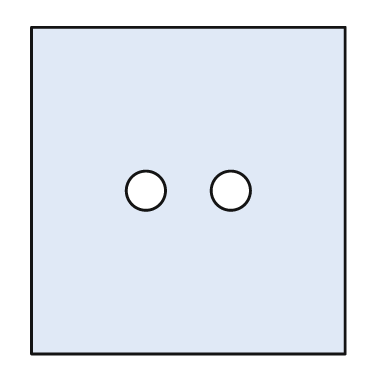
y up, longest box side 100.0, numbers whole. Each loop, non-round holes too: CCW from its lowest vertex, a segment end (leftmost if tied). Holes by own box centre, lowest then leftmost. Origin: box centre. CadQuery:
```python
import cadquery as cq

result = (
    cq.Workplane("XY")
    .moveTo(-48.0, -50.0)
    .lineTo(48.0, -50.0)
    .lineTo(48.0, 50.0)
    .lineTo(-48.0, 50.0)
    .close()
    .moveTo(-13.0, 0.0)
    .circle(6.0)
    .moveTo(13.0, 0.0)
    .circle(6.0)
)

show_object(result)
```